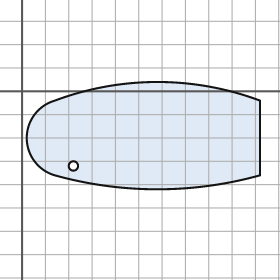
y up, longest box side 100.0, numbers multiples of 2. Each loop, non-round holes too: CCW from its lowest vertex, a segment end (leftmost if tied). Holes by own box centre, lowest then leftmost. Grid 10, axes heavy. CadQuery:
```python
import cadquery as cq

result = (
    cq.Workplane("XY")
    .moveTo(14.0, -36.0)
    .threePointArc((58.0, -42.0), (102.0, -36.0))
    .lineTo(102.0, -4.0)
    .threePointArc((58.0, 4.0), (14.0, -4.0))
    .threePointArc((2.0, -20.0), (14.0, -36.0))
    .close()
    .moveTo(22.0, -32.0)
    .circle(2.0)
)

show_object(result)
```